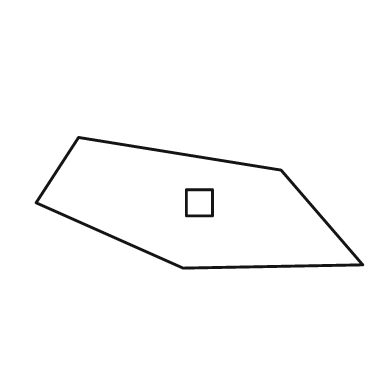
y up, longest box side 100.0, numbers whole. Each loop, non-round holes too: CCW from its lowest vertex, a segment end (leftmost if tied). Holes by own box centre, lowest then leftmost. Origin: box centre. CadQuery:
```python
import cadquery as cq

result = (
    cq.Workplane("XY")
    .moveTo(-5.0, -20.0)
    .lineTo(50.0, -19.0)
    .lineTo(25.0, 10.0)
    .lineTo(-37.0, 20.0)
    .lineTo(-50.0, 0.0)
    .close()
    .moveTo(-4.0, -4.0)
    .lineTo(4.0, -4.0)
    .lineTo(4.0, 4.0)
    .lineTo(-4.0, 4.0)
    .close()
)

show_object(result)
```